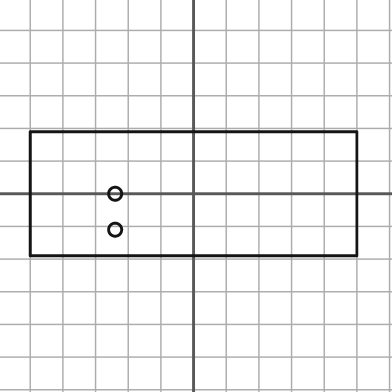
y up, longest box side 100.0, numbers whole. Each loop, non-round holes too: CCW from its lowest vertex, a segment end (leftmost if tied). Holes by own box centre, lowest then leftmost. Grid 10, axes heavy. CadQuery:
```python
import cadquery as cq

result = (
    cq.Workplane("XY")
    .moveTo(-50.0, -19.0)
    .lineTo(50.0, -19.0)
    .lineTo(50.0, 19.0)
    .lineTo(-50.0, 19.0)
    .close()
    .moveTo(-24.0, -11.0)
    .circle(2.0)
    .moveTo(-24.0, 0.0)
    .circle(2.0)
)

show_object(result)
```